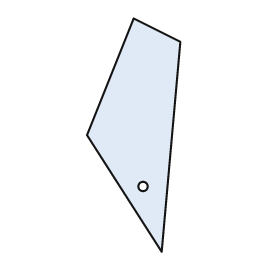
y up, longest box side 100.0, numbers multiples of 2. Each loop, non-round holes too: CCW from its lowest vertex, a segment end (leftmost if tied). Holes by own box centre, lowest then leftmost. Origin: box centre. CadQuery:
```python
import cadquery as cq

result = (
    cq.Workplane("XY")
    .moveTo(12.0, -50.0)
    .lineTo(20.0, 40.0)
    .lineTo(0.0, 50.0)
    .lineTo(-20.0, 0.0)
    .close()
    .moveTo(4.0, -22.0)
    .circle(2.0)
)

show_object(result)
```